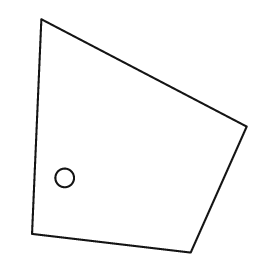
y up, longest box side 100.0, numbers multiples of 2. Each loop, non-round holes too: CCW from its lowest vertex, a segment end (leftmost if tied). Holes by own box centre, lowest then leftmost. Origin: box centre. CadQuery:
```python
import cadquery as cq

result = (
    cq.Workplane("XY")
    .moveTo(22.0, -50.0)
    .lineTo(46.0, 4.0)
    .lineTo(-42.0, 50.0)
    .lineTo(-46.0, -42.0)
    .close()
    .moveTo(-32.0, -18.0)
    .circle(4.0)
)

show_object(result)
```